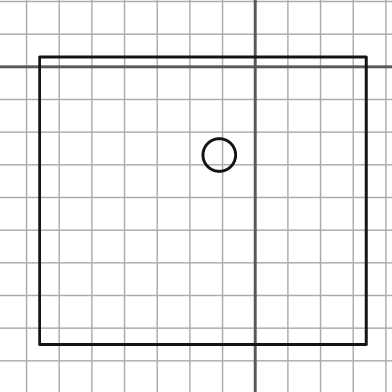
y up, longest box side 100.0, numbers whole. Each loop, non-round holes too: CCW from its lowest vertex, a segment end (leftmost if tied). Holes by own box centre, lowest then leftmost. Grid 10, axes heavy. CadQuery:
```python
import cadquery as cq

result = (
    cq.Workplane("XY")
    .moveTo(-66.0, -85.0)
    .lineTo(34.0, -85.0)
    .lineTo(34.0, 3.0)
    .lineTo(-66.0, 3.0)
    .close()
    .moveTo(-11.0, -27.0)
    .circle(5.0)
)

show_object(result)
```